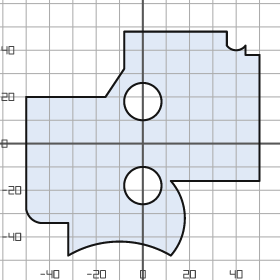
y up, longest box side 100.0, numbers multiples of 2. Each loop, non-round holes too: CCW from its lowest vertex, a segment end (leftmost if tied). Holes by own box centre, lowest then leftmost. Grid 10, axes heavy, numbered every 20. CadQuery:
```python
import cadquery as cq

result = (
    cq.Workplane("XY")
    .moveTo(-32.0, -48.0)
    .threePointArc((-10.0, -42.0), (12.0, -48.0))
    .threePointArc((18.0, -32.0), (12.0, -16.0))
    .lineTo(50.0, -16.0)
    .lineTo(50.0, 38.0)
    .lineTo(44.0, 38.0)
    .lineTo(44.0, 42.0)
    .threePointArc((40.0, 40.0), (36.0, 42.0))
    .lineTo(36.0, 48.0)
    .lineTo(-8.0, 48.0)
    .lineTo(-8.0, 32.0)
    .lineTo(-16.0, 20.0)
    .lineTo(-50.0, 20.0)
    .lineTo(-50.0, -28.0)
    .threePointArc((-48.0, -32.0), (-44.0, -34.0))
    .lineTo(-32.0, -34.0)
    .close()
    .moveTo(0.0, -18.0)
    .circle(8.0)
    .moveTo(0.0, 18.0)
    .circle(8.0)
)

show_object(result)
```